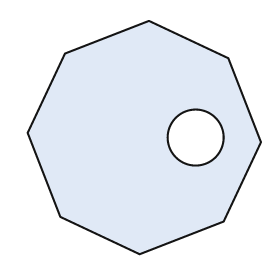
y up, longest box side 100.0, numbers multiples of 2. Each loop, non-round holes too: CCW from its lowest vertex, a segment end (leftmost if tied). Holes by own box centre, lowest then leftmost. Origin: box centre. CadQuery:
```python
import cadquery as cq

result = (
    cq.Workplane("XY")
    .moveTo(-2.0, -50.0)
    .lineTo(34.0, -36.0)
    .lineTo(50.0, -2.0)
    .lineTo(36.0, 34.0)
    .lineTo(2.0, 50.0)
    .lineTo(-34.0, 36.0)
    .lineTo(-50.0, 2.0)
    .lineTo(-36.0, -34.0)
    .close()
    .moveTo(22.0, 0.0)
    .circle(12.0)
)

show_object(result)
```